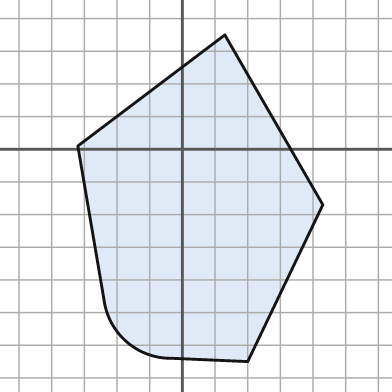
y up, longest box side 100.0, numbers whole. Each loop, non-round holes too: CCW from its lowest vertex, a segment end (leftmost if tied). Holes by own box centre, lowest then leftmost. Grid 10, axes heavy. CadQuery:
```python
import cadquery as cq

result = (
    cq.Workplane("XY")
    .moveTo(20.0, -65.0)
    .lineTo(43.0, -17.0)
    .lineTo(13.0, 35.0)
    .lineTo(-32.0, 1.0)
    .lineTo(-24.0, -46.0)
    .threePointArc((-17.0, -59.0), (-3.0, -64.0))
    .close()
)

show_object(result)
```